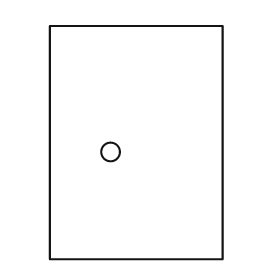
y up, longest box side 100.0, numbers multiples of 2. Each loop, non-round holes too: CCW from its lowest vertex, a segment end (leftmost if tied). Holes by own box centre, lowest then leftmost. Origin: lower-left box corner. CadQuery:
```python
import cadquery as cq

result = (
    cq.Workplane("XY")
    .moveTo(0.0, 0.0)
    .lineTo(74.0, 0.0)
    .lineTo(74.0, 100.0)
    .lineTo(0.0, 100.0)
    .close()
    .moveTo(26.0, 46.0)
    .circle(4.0)
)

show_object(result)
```